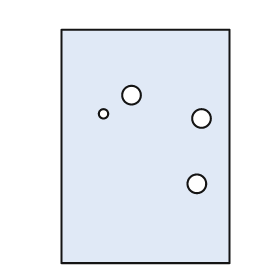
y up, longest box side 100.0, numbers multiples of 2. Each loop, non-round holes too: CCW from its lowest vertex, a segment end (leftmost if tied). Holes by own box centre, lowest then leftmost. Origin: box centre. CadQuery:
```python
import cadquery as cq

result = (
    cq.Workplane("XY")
    .moveTo(-36.0, -50.0)
    .lineTo(36.0, -50.0)
    .lineTo(36.0, 50.0)
    .lineTo(-36.0, 50.0)
    .close()
    .moveTo(22.0, -16.0)
    .circle(4.0)
    .moveTo(24.0, 12.0)
    .circle(4.0)
    .moveTo(-18.0, 14.0)
    .circle(2.0)
    .moveTo(-6.0, 22.0)
    .circle(4.0)
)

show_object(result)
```